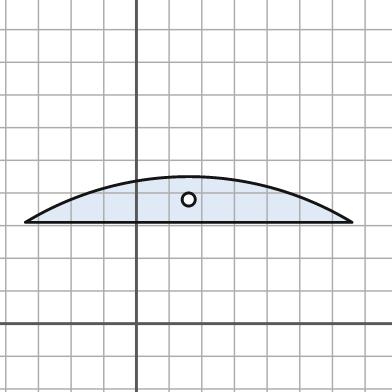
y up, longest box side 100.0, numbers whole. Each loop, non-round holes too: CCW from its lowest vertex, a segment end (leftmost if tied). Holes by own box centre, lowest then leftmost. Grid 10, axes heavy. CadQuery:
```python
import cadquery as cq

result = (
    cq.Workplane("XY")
    .moveTo(-34.0, 31.0)
    .lineTo(66.0, 31.0)
    .threePointArc((16.0, 45.0), (-34.0, 31.0))
    .close()
    .moveTo(16.0, 38.0)
    .circle(2.0)
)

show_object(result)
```